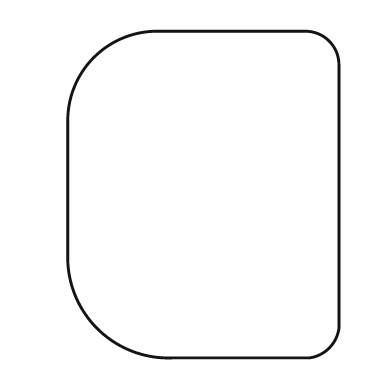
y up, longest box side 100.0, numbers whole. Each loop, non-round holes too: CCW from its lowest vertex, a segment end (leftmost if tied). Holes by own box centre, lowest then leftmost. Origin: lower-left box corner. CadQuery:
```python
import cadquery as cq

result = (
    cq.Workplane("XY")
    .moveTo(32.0, 0.0)
    .lineTo(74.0, 0.0)
    .threePointArc((80.0, 3.0), (83.0, 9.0))
    .lineTo(83.0, 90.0)
    .threePointArc((80.0, 97.0), (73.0, 100.0))
    .lineTo(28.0, 100.0)
    .threePointArc((8.0, 92.0), (0.0, 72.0))
    .lineTo(0.0, 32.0)
    .threePointArc((9.0, 9.0), (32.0, 0.0))
    .close()
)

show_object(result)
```